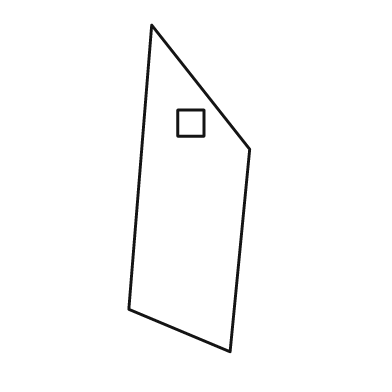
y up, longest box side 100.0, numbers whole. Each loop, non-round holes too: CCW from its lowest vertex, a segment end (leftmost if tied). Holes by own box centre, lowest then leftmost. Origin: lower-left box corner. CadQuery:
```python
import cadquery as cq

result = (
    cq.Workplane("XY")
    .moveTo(31.0, 0.0)
    .lineTo(37.0, 62.0)
    .lineTo(7.0, 100.0)
    .lineTo(0.0, 13.0)
    .close()
    .moveTo(15.0, 66.0)
    .lineTo(23.0, 66.0)
    .lineTo(23.0, 74.0)
    .lineTo(15.0, 74.0)
    .close()
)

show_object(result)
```